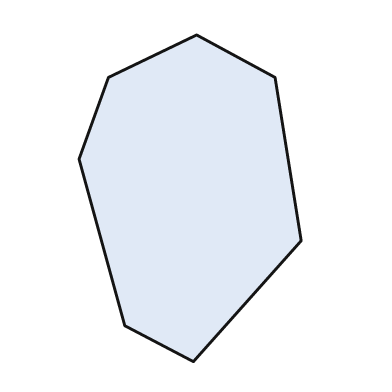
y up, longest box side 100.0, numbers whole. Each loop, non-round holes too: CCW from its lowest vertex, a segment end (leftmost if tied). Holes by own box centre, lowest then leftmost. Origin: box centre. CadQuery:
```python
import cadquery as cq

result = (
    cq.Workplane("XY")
    .moveTo(1.0, -50.0)
    .lineTo(34.0, -13.0)
    .lineTo(26.0, 37.0)
    .lineTo(2.0, 50.0)
    .lineTo(-25.0, 37.0)
    .lineTo(-34.0, 12.0)
    .lineTo(-20.0, -39.0)
    .close()
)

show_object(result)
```